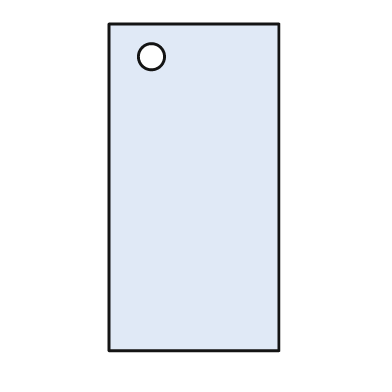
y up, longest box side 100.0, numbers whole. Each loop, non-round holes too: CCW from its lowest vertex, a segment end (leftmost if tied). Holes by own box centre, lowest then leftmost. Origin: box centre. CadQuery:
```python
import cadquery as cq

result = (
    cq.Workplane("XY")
    .moveTo(-26.0, -50.0)
    .lineTo(26.0, -50.0)
    .lineTo(26.0, 50.0)
    .lineTo(-26.0, 50.0)
    .close()
    .moveTo(-13.0, 40.0)
    .circle(4.0)
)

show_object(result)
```